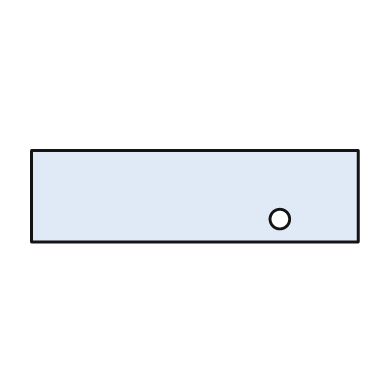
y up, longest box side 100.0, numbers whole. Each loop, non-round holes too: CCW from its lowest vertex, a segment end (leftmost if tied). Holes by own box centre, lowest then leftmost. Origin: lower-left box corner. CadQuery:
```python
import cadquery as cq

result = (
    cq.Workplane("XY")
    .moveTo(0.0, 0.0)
    .lineTo(100.0, 0.0)
    .lineTo(100.0, 28.0)
    .lineTo(0.0, 28.0)
    .close()
    .moveTo(76.0, 7.0)
    .circle(3.0)
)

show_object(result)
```